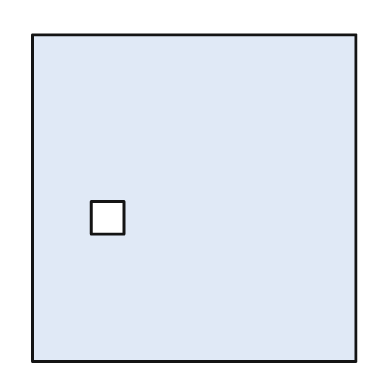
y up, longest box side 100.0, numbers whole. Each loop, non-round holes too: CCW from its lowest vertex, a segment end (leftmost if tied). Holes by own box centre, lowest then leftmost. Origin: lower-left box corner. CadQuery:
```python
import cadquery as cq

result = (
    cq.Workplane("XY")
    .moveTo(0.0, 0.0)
    .lineTo(99.0, 0.0)
    .lineTo(99.0, 100.0)
    .lineTo(0.0, 100.0)
    .close()
    .moveTo(18.0, 39.0)
    .lineTo(28.0, 39.0)
    .lineTo(28.0, 49.0)
    .lineTo(18.0, 49.0)
    .close()
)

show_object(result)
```